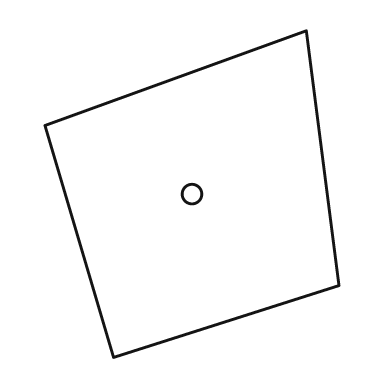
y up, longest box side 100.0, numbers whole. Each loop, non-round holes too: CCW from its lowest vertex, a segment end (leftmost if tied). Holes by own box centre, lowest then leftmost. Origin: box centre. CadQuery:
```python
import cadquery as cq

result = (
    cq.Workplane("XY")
    .moveTo(-24.0, -50.0)
    .lineTo(45.0, -28.0)
    .lineTo(35.0, 50.0)
    .lineTo(-45.0, 21.0)
    .close()
    .moveTo(0.0, 0.0)
    .circle(3.0)
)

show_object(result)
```